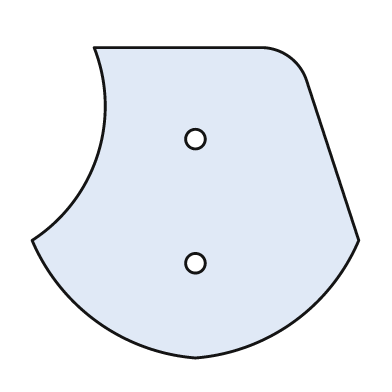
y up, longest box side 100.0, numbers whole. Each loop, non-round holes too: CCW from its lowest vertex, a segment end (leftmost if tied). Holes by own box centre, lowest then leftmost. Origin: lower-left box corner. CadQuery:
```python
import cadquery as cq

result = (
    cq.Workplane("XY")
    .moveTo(50.0, 0.0)
    .threePointArc((80.0, 11.0), (100.0, 36.0))
    .lineTo(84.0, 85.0)
    .threePointArc((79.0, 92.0), (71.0, 95.0))
    .lineTo(19.0, 95.0)
    .threePointArc((20.0, 62.0), (0.0, 36.0))
    .threePointArc((20.0, 11.0), (50.0, 0.0))
    .close()
    .moveTo(50.0, 29.0)
    .circle(3.0)
    .moveTo(50.0, 67.0)
    .circle(3.0)
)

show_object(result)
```